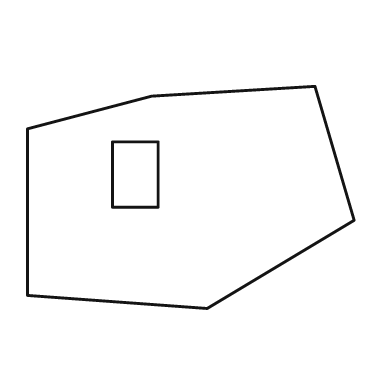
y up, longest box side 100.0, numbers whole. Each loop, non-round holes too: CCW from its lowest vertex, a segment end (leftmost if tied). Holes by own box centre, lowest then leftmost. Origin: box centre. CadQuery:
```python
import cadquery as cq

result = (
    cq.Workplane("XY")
    .moveTo(5.0, -34.0)
    .lineTo(50.0, -7.0)
    .lineTo(38.0, 34.0)
    .lineTo(-12.0, 31.0)
    .lineTo(-50.0, 21.0)
    .lineTo(-50.0, -30.0)
    .close()
    .moveTo(-24.0, -3.0)
    .lineTo(-10.0, -3.0)
    .lineTo(-10.0, 17.0)
    .lineTo(-24.0, 17.0)
    .close()
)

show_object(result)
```